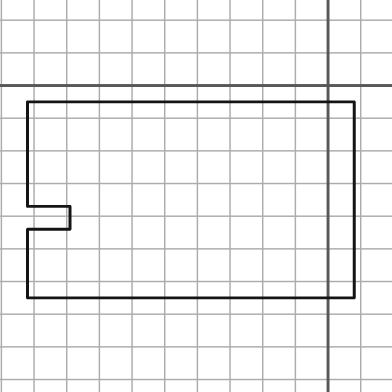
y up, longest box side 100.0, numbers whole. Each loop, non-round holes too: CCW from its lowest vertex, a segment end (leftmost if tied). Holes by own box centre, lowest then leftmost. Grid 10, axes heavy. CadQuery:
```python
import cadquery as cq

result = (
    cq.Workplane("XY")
    .moveTo(-92.0, -65.0)
    .lineTo(8.0, -65.0)
    .lineTo(8.0, -5.0)
    .lineTo(-92.0, -5.0)
    .lineTo(-92.0, -37.0)
    .lineTo(-79.0, -37.0)
    .lineTo(-79.0, -44.0)
    .lineTo(-92.0, -44.0)
    .close()
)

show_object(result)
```